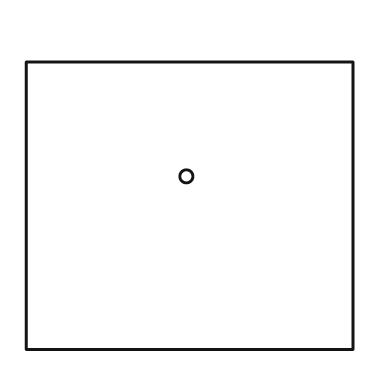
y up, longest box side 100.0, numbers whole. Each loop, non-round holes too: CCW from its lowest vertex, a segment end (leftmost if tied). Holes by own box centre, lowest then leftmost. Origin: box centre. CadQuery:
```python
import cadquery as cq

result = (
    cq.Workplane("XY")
    .moveTo(-50.0, -44.0)
    .lineTo(50.0, -44.0)
    .lineTo(50.0, 44.0)
    .lineTo(-50.0, 44.0)
    .close()
    .moveTo(-1.0, 9.0)
    .circle(2.0)
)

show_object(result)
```